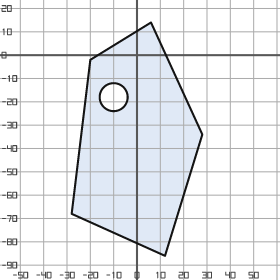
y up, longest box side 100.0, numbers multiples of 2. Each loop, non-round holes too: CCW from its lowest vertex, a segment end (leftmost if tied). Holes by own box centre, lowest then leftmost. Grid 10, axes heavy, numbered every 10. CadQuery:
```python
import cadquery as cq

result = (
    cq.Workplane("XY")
    .moveTo(12.0, -86.0)
    .lineTo(28.0, -34.0)
    .lineTo(6.0, 14.0)
    .lineTo(-20.0, -2.0)
    .lineTo(-28.0, -68.0)
    .close()
    .moveTo(-10.0, -18.0)
    .circle(6.0)
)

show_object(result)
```